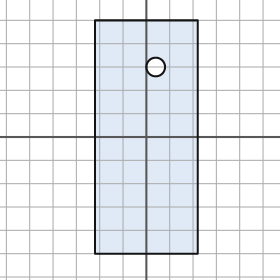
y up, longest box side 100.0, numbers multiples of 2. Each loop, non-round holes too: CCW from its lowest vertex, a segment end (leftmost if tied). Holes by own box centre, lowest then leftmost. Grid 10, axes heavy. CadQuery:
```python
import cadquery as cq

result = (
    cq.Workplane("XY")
    .moveTo(-22.0, -50.0)
    .lineTo(22.0, -50.0)
    .lineTo(22.0, 50.0)
    .lineTo(-22.0, 50.0)
    .close()
    .moveTo(4.0, 30.0)
    .circle(4.0)
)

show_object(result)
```